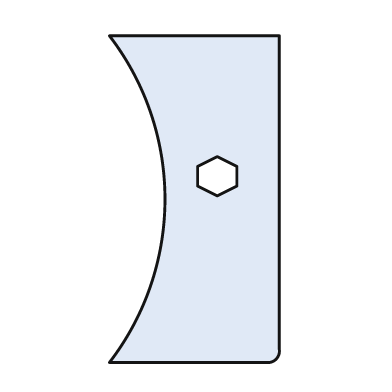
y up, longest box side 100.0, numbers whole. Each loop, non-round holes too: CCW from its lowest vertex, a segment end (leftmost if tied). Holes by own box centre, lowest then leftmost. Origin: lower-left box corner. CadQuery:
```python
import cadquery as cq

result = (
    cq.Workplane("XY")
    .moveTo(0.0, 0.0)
    .lineTo(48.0, 0.0)
    .threePointArc((51.0, 1.0), (52.0, 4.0))
    .lineTo(52.0, 100.0)
    .lineTo(0.0, 100.0)
    .threePointArc((17.0, 50.0), (0.0, 0.0))
    .close()
    .moveTo(33.0, 51.0)
    .lineTo(39.0, 54.0)
    .lineTo(39.0, 60.0)
    .lineTo(33.0, 63.0)
    .lineTo(27.0, 60.0)
    .lineTo(27.0, 54.0)
    .close()
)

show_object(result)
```